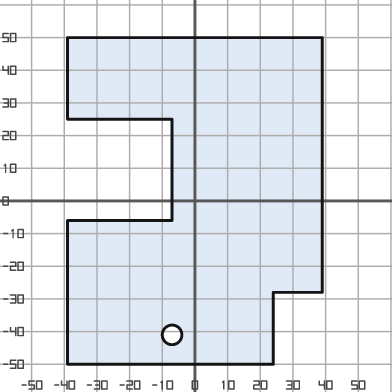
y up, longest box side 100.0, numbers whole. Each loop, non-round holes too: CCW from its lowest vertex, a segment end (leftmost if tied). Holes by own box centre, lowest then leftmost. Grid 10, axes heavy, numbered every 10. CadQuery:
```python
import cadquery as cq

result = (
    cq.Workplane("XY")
    .moveTo(-39.0, -50.0)
    .lineTo(24.0, -50.0)
    .lineTo(24.0, -28.0)
    .lineTo(39.0, -28.0)
    .lineTo(39.0, 50.0)
    .lineTo(-39.0, 50.0)
    .lineTo(-39.0, 25.0)
    .lineTo(-7.0, 25.0)
    .lineTo(-7.0, -6.0)
    .lineTo(-39.0, -6.0)
    .close()
    .moveTo(-7.0, -41.0)
    .circle(3.0)
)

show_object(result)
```